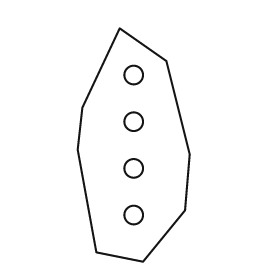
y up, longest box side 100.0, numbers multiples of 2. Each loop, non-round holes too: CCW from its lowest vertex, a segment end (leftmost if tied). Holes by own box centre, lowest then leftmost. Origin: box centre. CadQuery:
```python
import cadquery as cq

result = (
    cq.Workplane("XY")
    .moveTo(4.0, -50.0)
    .lineTo(22.0, -28.0)
    .lineTo(24.0, -4.0)
    .lineTo(14.0, 36.0)
    .lineTo(-6.0, 50.0)
    .lineTo(-22.0, 16.0)
    .lineTo(-24.0, -2.0)
    .lineTo(-16.0, -46.0)
    .close()
    .moveTo(0.0, -30.0)
    .circle(4.0)
    .moveTo(0.0, -10.0)
    .circle(4.0)
    .moveTo(0.0, 10.0)
    .circle(4.0)
    .moveTo(0.0, 30.0)
    .circle(4.0)
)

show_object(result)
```